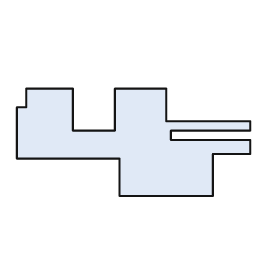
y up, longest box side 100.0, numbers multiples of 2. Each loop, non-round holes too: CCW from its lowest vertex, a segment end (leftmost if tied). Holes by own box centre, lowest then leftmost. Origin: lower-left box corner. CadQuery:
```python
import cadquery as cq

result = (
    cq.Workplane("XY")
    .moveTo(44.0, 0.0)
    .lineTo(84.0, 0.0)
    .lineTo(84.0, 18.0)
    .lineTo(100.0, 18.0)
    .lineTo(100.0, 24.0)
    .lineTo(66.0, 24.0)
    .lineTo(66.0, 28.0)
    .lineTo(100.0, 28.0)
    .lineTo(100.0, 32.0)
    .lineTo(64.0, 32.0)
    .lineTo(64.0, 46.0)
    .lineTo(42.0, 46.0)
    .lineTo(42.0, 28.0)
    .lineTo(24.0, 28.0)
    .lineTo(24.0, 46.0)
    .lineTo(4.0, 46.0)
    .lineTo(4.0, 38.0)
    .lineTo(0.0, 38.0)
    .lineTo(0.0, 16.0)
    .lineTo(44.0, 16.0)
    .close()
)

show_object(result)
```